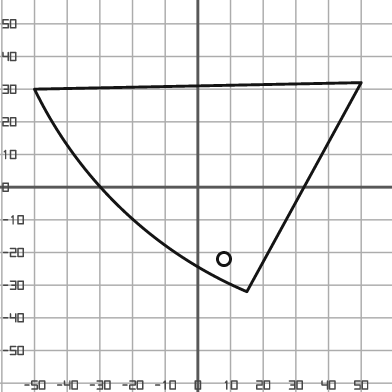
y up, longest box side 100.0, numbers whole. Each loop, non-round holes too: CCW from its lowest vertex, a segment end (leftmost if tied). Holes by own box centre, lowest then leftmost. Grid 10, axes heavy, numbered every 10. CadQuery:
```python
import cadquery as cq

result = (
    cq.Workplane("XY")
    .moveTo(15.0, -32.0)
    .lineTo(50.0, 32.0)
    .lineTo(-50.0, 30.0)
    .threePointArc((-23.0, -7.0), (15.0, -32.0))
    .close()
    .moveTo(8.0, -22.0)
    .circle(2.0)
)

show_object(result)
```